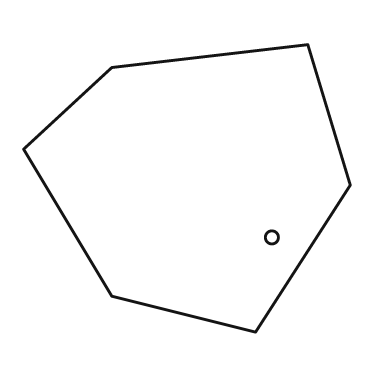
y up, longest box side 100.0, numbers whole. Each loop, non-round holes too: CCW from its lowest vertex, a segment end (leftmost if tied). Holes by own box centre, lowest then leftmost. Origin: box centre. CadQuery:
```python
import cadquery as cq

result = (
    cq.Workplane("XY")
    .moveTo(21.0, -44.0)
    .lineTo(50.0, 1.0)
    .lineTo(37.0, 44.0)
    .lineTo(-23.0, 37.0)
    .lineTo(-50.0, 12.0)
    .lineTo(-23.0, -33.0)
    .close()
    .moveTo(26.0, -15.0)
    .circle(2.0)
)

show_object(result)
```